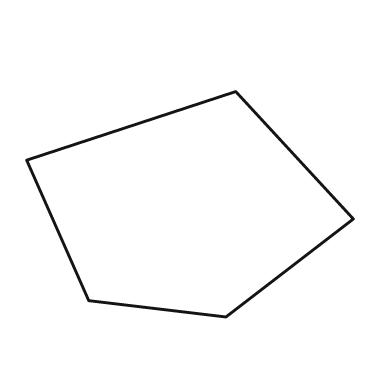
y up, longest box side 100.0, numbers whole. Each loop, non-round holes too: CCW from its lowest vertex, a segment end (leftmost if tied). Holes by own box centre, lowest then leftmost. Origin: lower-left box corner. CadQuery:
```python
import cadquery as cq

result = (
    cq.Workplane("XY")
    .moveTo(61.0, 0.0)
    .lineTo(100.0, 30.0)
    .lineTo(64.0, 69.0)
    .lineTo(0.0, 48.0)
    .lineTo(19.0, 5.0)
    .close()
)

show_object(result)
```